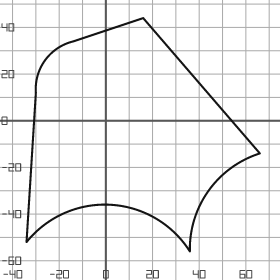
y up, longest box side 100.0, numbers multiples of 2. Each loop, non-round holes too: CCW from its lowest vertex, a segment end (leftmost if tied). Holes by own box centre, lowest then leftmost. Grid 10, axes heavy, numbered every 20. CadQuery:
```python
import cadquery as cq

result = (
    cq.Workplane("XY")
    .moveTo(36.0, -56.0)
    .threePointArc((44.0, -30.0), (66.0, -14.0))
    .lineTo(16.0, 44.0)
    .lineTo(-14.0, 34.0)
    .threePointArc((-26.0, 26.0), (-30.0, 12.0))
    .lineTo(-34.0, -52.0)
    .threePointArc((2.0, -36.0), (36.0, -56.0))
    .close()
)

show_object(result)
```